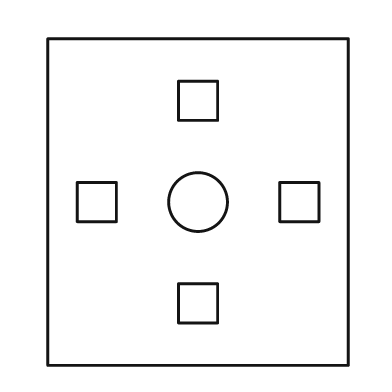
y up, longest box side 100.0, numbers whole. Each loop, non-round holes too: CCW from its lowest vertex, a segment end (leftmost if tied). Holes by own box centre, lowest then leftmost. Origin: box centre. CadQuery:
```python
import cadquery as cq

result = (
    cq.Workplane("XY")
    .moveTo(-46.0, -50.0)
    .lineTo(46.0, -50.0)
    .lineTo(46.0, 50.0)
    .lineTo(-46.0, 50.0)
    .close()
    .moveTo(-6.0, -37.0)
    .lineTo(6.0, -37.0)
    .lineTo(6.0, -25.0)
    .lineTo(-6.0, -25.0)
    .close()
    .moveTo(-37.0, -6.0)
    .lineTo(-25.0, -6.0)
    .lineTo(-25.0, 6.0)
    .lineTo(-37.0, 6.0)
    .close()
    .moveTo(0.0, 0.0)
    .circle(9.0)
    .moveTo(25.0, -6.0)
    .lineTo(37.0, -6.0)
    .lineTo(37.0, 6.0)
    .lineTo(25.0, 6.0)
    .close()
    .moveTo(-6.0, 25.0)
    .lineTo(6.0, 25.0)
    .lineTo(6.0, 37.0)
    .lineTo(-6.0, 37.0)
    .close()
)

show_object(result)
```